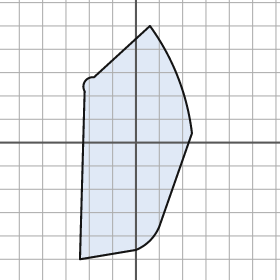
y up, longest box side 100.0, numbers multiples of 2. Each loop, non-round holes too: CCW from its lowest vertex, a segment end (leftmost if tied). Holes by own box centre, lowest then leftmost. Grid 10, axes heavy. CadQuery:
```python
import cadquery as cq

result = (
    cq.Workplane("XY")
    .moveTo(-24.0, -50.0)
    .lineTo(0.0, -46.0)
    .threePointArc((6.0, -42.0), (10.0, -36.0))
    .lineTo(24.0, 4.0)
    .threePointArc((18.0, 28.0), (6.0, 50.0))
    .lineTo(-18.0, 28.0)
    .threePointArc((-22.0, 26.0), (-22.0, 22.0))
    .close()
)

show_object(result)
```